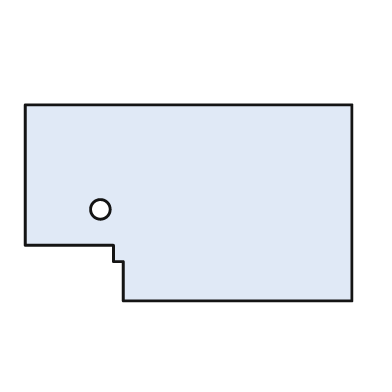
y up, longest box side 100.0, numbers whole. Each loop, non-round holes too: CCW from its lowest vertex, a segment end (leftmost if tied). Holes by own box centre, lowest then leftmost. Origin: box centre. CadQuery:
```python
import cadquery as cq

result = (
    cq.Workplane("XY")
    .moveTo(-20.0, -30.0)
    .lineTo(50.0, -30.0)
    .lineTo(50.0, 30.0)
    .lineTo(-50.0, 30.0)
    .lineTo(-50.0, -13.0)
    .lineTo(-23.0, -13.0)
    .lineTo(-23.0, -18.0)
    .lineTo(-20.0, -18.0)
    .close()
    .moveTo(-27.0, -2.0)
    .circle(3.0)
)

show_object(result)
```